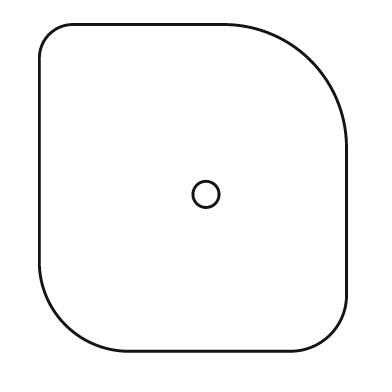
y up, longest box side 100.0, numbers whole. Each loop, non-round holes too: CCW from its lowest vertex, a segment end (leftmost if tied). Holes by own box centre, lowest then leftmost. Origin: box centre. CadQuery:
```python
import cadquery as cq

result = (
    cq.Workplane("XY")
    .moveTo(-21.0, -50.0)
    .lineTo(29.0, -50.0)
    .threePointArc((42.0, -45.0), (47.0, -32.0))
    .lineTo(47.0, 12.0)
    .threePointArc((36.0, 39.0), (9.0, 50.0))
    .lineTo(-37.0, 50.0)
    .threePointArc((-44.0, 47.0), (-47.0, 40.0))
    .lineTo(-47.0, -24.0)
    .threePointArc((-39.0, -42.0), (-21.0, -50.0))
    .close()
    .moveTo(4.0, -2.0)
    .circle(4.0)
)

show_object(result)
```